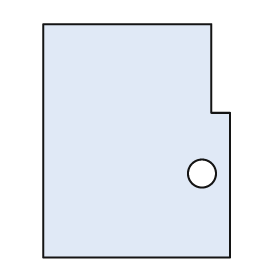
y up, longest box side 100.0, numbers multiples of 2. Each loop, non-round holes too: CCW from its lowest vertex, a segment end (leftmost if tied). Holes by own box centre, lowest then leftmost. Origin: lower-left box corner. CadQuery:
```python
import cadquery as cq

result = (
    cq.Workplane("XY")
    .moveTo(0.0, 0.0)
    .lineTo(80.0, 0.0)
    .lineTo(80.0, 62.0)
    .lineTo(72.0, 62.0)
    .lineTo(72.0, 100.0)
    .lineTo(0.0, 100.0)
    .close()
    .moveTo(68.0, 36.0)
    .circle(6.0)
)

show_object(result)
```